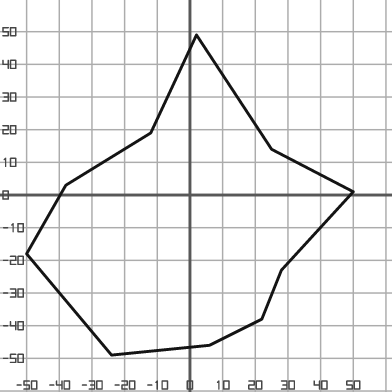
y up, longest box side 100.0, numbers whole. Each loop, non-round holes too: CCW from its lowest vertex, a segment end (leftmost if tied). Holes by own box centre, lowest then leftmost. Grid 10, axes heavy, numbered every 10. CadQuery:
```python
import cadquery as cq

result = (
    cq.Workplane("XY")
    .moveTo(-24.0, -49.0)
    .lineTo(6.0, -46.0)
    .lineTo(22.0, -38.0)
    .lineTo(28.0, -23.0)
    .lineTo(50.0, 1.0)
    .lineTo(25.0, 14.0)
    .lineTo(2.0, 49.0)
    .lineTo(-12.0, 19.0)
    .lineTo(-38.0, 3.0)
    .lineTo(-50.0, -18.0)
    .close()
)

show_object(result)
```